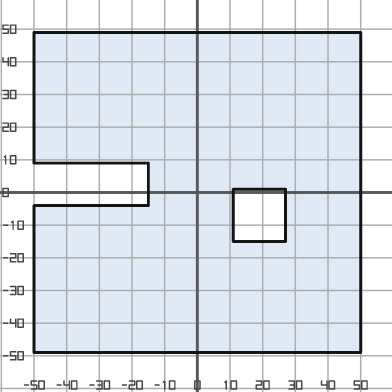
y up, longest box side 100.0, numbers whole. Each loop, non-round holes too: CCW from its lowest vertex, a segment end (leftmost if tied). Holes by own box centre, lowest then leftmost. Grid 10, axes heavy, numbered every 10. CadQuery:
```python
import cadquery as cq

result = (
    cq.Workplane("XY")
    .moveTo(-50.0, -49.0)
    .lineTo(50.0, -49.0)
    .lineTo(50.0, 49.0)
    .lineTo(-50.0, 49.0)
    .lineTo(-50.0, 9.0)
    .lineTo(-15.0, 9.0)
    .lineTo(-15.0, -4.0)
    .lineTo(-50.0, -4.0)
    .close()
    .moveTo(11.0, -15.0)
    .lineTo(27.0, -15.0)
    .lineTo(27.0, 1.0)
    .lineTo(11.0, 1.0)
    .close()
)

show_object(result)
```